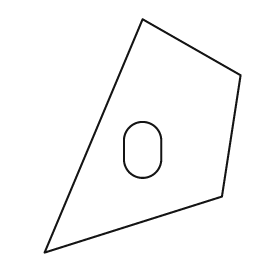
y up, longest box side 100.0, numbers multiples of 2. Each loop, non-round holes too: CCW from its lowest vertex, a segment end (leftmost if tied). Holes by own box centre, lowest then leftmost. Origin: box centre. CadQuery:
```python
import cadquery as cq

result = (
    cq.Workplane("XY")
    .moveTo(-42.0, -50.0)
    .lineTo(34.0, -26.0)
    .lineTo(42.0, 26.0)
    .lineTo(0.0, 50.0)
    .close()
    .moveTo(-8.0, -10.0)
    .threePointArc((0.0, -18.0), (8.0, -10.0))
    .lineTo(8.0, -2.0)
    .threePointArc((0.0, 6.0), (-8.0, -2.0))
    .close()
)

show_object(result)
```